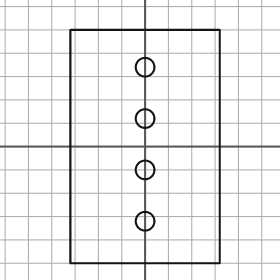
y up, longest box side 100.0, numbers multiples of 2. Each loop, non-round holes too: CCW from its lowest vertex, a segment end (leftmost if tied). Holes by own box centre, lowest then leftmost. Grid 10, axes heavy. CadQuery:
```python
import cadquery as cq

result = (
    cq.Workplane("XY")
    .moveTo(-32.0, -50.0)
    .lineTo(32.0, -50.0)
    .lineTo(32.0, 50.0)
    .lineTo(-32.0, 50.0)
    .close()
    .moveTo(0.0, -32.0)
    .circle(4.0)
    .moveTo(0.0, -10.0)
    .circle(4.0)
    .moveTo(0.0, 12.0)
    .circle(4.0)
    .moveTo(0.0, 34.0)
    .circle(4.0)
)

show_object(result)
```